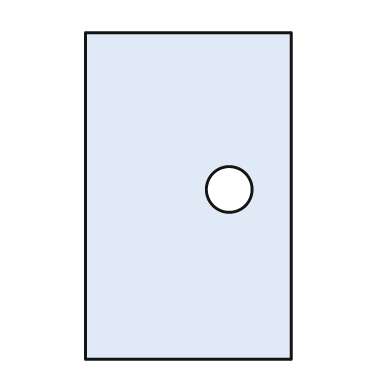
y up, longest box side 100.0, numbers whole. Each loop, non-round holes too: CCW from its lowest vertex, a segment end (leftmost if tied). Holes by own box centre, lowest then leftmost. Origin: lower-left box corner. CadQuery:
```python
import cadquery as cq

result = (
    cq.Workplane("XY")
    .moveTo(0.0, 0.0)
    .lineTo(63.0, 0.0)
    .lineTo(63.0, 100.0)
    .lineTo(0.0, 100.0)
    .close()
    .moveTo(44.0, 52.0)
    .circle(7.0)
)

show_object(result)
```